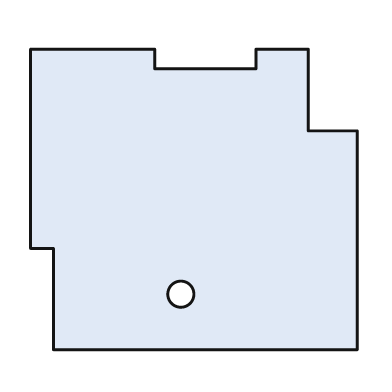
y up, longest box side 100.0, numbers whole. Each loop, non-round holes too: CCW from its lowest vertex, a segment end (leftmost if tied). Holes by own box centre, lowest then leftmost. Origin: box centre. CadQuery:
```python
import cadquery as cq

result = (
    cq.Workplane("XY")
    .moveTo(-43.0, -46.0)
    .lineTo(50.0, -46.0)
    .lineTo(50.0, 21.0)
    .lineTo(35.0, 21.0)
    .lineTo(35.0, 46.0)
    .lineTo(19.0, 46.0)
    .lineTo(19.0, 40.0)
    .lineTo(-12.0, 40.0)
    .lineTo(-12.0, 46.0)
    .lineTo(-50.0, 46.0)
    .lineTo(-50.0, -15.0)
    .lineTo(-43.0, -15.0)
    .close()
    .moveTo(-4.0, -29.0)
    .circle(4.0)
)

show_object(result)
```